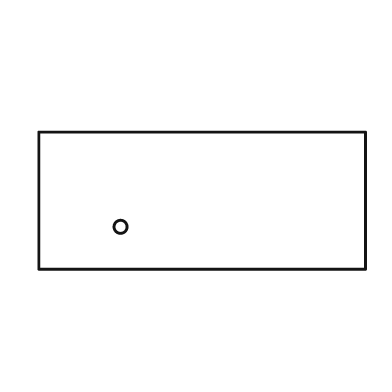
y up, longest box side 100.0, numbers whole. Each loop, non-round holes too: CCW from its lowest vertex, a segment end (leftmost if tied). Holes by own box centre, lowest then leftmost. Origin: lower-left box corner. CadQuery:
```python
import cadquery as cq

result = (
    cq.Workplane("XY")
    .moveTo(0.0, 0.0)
    .lineTo(100.0, 0.0)
    .lineTo(100.0, 42.0)
    .lineTo(0.0, 42.0)
    .close()
    .moveTo(25.0, 13.0)
    .circle(2.0)
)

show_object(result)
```